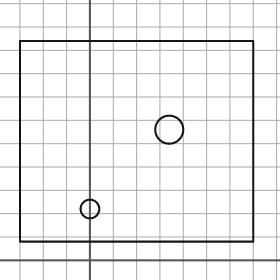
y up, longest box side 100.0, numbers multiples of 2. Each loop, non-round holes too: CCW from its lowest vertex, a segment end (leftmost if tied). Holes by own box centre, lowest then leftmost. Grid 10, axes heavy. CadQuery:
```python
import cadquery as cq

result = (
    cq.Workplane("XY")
    .moveTo(-30.0, 8.0)
    .lineTo(70.0, 8.0)
    .lineTo(70.0, 94.0)
    .lineTo(-30.0, 94.0)
    .close()
    .moveTo(0.0, 22.0)
    .circle(4.0)
    .moveTo(34.0, 56.0)
    .circle(6.0)
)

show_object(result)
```